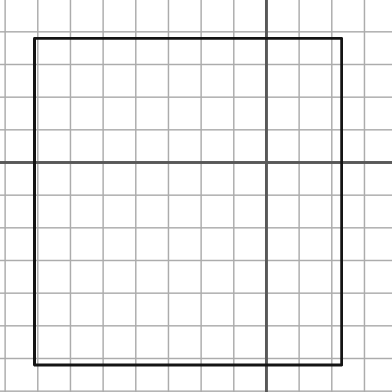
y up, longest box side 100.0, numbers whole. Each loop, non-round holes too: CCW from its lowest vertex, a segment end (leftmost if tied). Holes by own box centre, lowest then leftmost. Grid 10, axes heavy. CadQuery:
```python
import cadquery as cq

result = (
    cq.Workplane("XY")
    .moveTo(-71.0, -62.0)
    .lineTo(23.0, -62.0)
    .lineTo(23.0, 38.0)
    .lineTo(-71.0, 38.0)
    .close()
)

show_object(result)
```